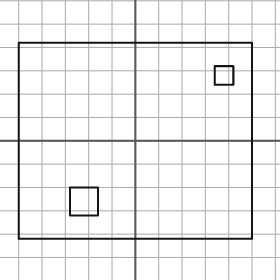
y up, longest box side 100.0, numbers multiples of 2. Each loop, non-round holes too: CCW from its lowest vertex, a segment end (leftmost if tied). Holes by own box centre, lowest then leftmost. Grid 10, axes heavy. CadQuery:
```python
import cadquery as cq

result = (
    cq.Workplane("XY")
    .moveTo(-50.0, -42.0)
    .lineTo(50.0, -42.0)
    .lineTo(50.0, 42.0)
    .lineTo(-50.0, 42.0)
    .close()
    .moveTo(-28.0, -32.0)
    .lineTo(-16.0, -32.0)
    .lineTo(-16.0, -20.0)
    .lineTo(-28.0, -20.0)
    .close()
    .moveTo(34.0, 24.0)
    .lineTo(42.0, 24.0)
    .lineTo(42.0, 32.0)
    .lineTo(34.0, 32.0)
    .close()
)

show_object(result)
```